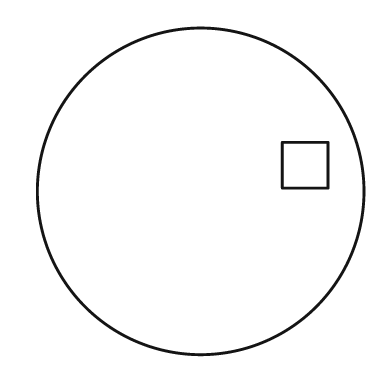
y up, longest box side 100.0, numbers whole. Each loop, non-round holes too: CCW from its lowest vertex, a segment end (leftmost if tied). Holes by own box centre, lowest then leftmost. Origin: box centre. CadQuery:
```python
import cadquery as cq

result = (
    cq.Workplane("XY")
    .moveTo(0.0, 0.0)
    .circle(50.0)
    .moveTo(25.0, 1.0)
    .lineTo(39.0, 1.0)
    .lineTo(39.0, 15.0)
    .lineTo(25.0, 15.0)
    .close()
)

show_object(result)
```